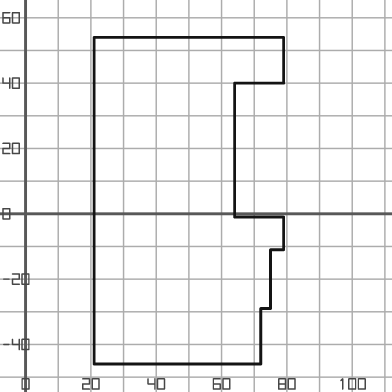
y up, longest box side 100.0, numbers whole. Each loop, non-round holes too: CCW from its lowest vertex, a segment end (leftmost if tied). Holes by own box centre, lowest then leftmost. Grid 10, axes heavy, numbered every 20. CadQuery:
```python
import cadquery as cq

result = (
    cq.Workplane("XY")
    .moveTo(21.0, -46.0)
    .lineTo(72.0, -46.0)
    .lineTo(72.0, -29.0)
    .lineTo(75.0, -29.0)
    .lineTo(75.0, -11.0)
    .lineTo(79.0, -11.0)
    .lineTo(79.0, -1.0)
    .lineTo(64.0, -1.0)
    .lineTo(64.0, 40.0)
    .lineTo(79.0, 40.0)
    .lineTo(79.0, 54.0)
    .lineTo(21.0, 54.0)
    .close()
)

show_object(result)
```